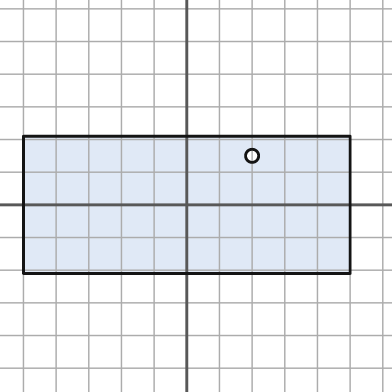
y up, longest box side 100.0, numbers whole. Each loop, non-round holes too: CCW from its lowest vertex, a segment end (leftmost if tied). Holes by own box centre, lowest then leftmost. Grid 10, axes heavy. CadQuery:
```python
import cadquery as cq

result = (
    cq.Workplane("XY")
    .moveTo(-50.0, -21.0)
    .lineTo(50.0, -21.0)
    .lineTo(50.0, 21.0)
    .lineTo(-50.0, 21.0)
    .close()
    .moveTo(20.0, 15.0)
    .circle(2.0)
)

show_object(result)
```